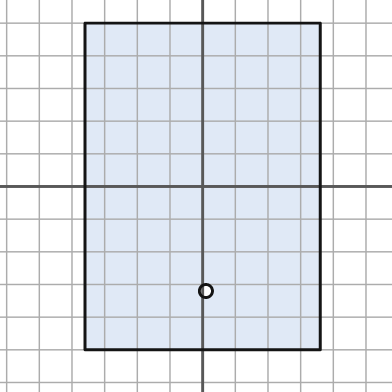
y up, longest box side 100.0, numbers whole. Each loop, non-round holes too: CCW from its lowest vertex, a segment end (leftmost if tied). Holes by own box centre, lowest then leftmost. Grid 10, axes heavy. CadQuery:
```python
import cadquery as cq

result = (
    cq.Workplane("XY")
    .moveTo(-36.0, -50.0)
    .lineTo(36.0, -50.0)
    .lineTo(36.0, 50.0)
    .lineTo(-36.0, 50.0)
    .close()
    .moveTo(1.0, -32.0)
    .circle(2.0)
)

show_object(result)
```